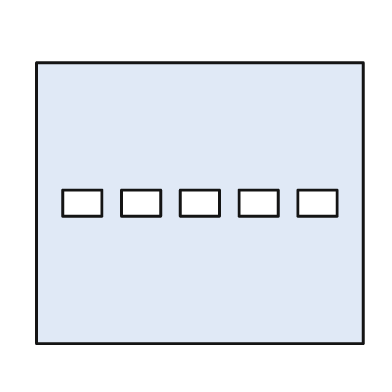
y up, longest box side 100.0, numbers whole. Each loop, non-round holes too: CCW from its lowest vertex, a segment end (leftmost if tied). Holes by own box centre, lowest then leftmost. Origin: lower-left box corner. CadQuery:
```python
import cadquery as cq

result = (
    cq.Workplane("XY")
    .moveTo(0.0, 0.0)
    .lineTo(100.0, 0.0)
    .lineTo(100.0, 86.0)
    .lineTo(0.0, 86.0)
    .close()
    .moveTo(8.0, 39.0)
    .lineTo(20.0, 39.0)
    .lineTo(20.0, 47.0)
    .lineTo(8.0, 47.0)
    .close()
    .moveTo(26.0, 39.0)
    .lineTo(38.0, 39.0)
    .lineTo(38.0, 47.0)
    .lineTo(26.0, 47.0)
    .close()
    .moveTo(44.0, 39.0)
    .lineTo(56.0, 39.0)
    .lineTo(56.0, 47.0)
    .lineTo(44.0, 47.0)
    .close()
    .moveTo(62.0, 39.0)
    .lineTo(74.0, 39.0)
    .lineTo(74.0, 47.0)
    .lineTo(62.0, 47.0)
    .close()
    .moveTo(80.0, 39.0)
    .lineTo(92.0, 39.0)
    .lineTo(92.0, 47.0)
    .lineTo(80.0, 47.0)
    .close()
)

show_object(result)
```